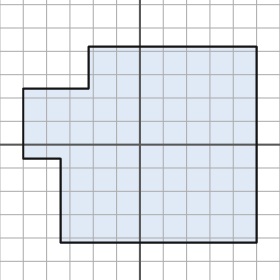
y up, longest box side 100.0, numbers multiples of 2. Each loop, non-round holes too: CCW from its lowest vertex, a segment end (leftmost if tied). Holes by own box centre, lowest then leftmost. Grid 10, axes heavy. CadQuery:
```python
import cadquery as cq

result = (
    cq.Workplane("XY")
    .moveTo(-34.0, -42.0)
    .lineTo(50.0, -42.0)
    .lineTo(50.0, 42.0)
    .lineTo(-22.0, 42.0)
    .lineTo(-22.0, 24.0)
    .lineTo(-50.0, 24.0)
    .lineTo(-50.0, -6.0)
    .lineTo(-34.0, -6.0)
    .close()
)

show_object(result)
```